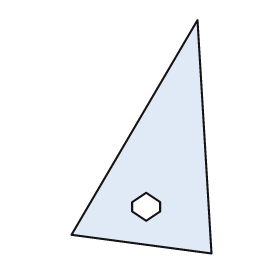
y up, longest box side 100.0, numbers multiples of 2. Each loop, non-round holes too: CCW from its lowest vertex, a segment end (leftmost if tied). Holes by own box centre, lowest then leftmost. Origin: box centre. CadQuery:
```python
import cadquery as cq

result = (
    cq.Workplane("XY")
    .moveTo(30.0, -50.0)
    .lineTo(24.0, 50.0)
    .lineTo(-30.0, -42.0)
    .close()
    .moveTo(2.0, -36.0)
    .lineTo(8.0, -32.0)
    .lineTo(8.0, -28.0)
    .lineTo(2.0, -24.0)
    .lineTo(-4.0, -28.0)
    .lineTo(-4.0, -32.0)
    .close()
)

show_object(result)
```